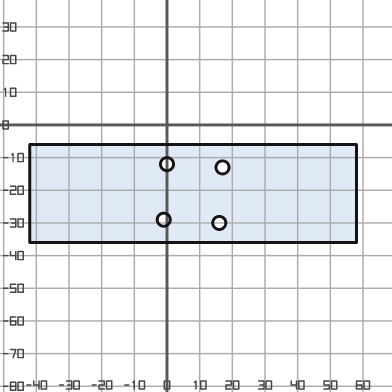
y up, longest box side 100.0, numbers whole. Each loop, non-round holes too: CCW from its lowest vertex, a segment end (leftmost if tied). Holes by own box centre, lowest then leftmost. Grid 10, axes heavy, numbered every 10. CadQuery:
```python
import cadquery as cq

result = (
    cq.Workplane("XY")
    .moveTo(-42.0, -36.0)
    .lineTo(58.0, -36.0)
    .lineTo(58.0, -6.0)
    .lineTo(-42.0, -6.0)
    .close()
    .moveTo(16.0, -30.0)
    .circle(2.0)
    .moveTo(-1.0, -29.0)
    .circle(2.0)
    .moveTo(17.0, -13.0)
    .circle(2.0)
    .moveTo(0.0, -12.0)
    .circle(2.0)
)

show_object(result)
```